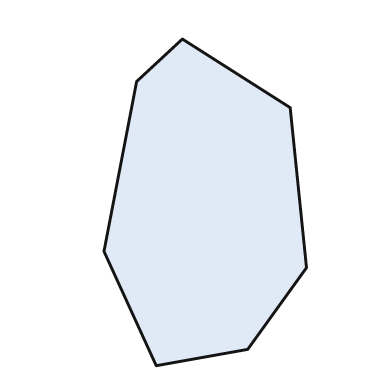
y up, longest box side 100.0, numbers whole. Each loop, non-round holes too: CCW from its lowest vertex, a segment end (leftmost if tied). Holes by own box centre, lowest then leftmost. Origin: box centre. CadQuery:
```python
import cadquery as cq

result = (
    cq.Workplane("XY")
    .moveTo(-15.0, -50.0)
    .lineTo(13.0, -45.0)
    .lineTo(31.0, -20.0)
    .lineTo(26.0, 29.0)
    .lineTo(-7.0, 50.0)
    .lineTo(-21.0, 37.0)
    .lineTo(-31.0, -15.0)
    .close()
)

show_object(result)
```